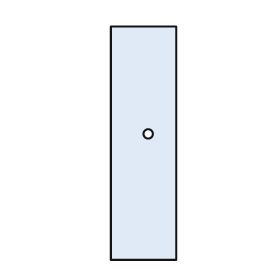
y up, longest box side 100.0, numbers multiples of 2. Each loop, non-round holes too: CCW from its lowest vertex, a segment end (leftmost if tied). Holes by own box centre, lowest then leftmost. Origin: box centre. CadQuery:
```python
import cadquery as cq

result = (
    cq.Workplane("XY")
    .moveTo(-14.0, -50.0)
    .lineTo(14.0, -50.0)
    .lineTo(14.0, 50.0)
    .lineTo(-14.0, 50.0)
    .close()
    .moveTo(2.0, 4.0)
    .circle(2.0)
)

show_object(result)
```